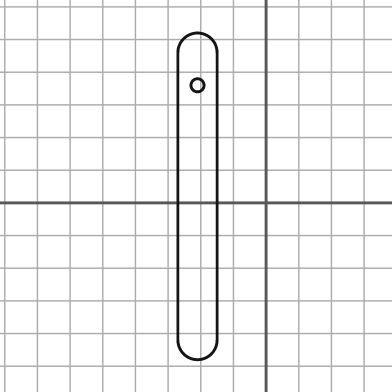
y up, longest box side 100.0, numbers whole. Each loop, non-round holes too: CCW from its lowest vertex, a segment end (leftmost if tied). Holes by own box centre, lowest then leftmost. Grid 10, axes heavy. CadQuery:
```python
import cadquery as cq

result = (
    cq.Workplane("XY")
    .moveTo(-27.0, -42.0)
    .threePointArc((-21.0, -48.0), (-15.0, -42.0))
    .lineTo(-15.0, 46.0)
    .threePointArc((-21.0, 52.0), (-27.0, 46.0))
    .close()
    .moveTo(-21.0, 36.0)
    .circle(2.0)
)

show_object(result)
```